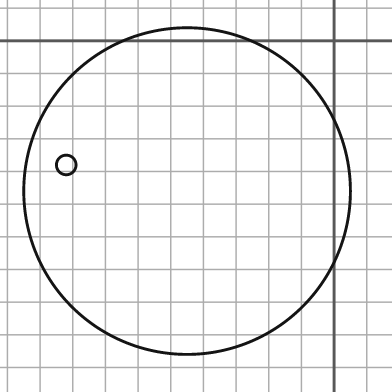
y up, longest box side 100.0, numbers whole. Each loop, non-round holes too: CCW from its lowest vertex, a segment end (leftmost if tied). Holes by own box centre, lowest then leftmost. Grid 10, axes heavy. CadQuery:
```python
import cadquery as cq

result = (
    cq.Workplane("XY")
    .moveTo(-45.0, -46.0)
    .circle(50.0)
    .moveTo(-82.0, -38.0)
    .circle(3.0)
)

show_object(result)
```